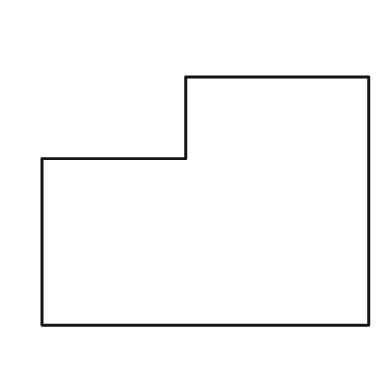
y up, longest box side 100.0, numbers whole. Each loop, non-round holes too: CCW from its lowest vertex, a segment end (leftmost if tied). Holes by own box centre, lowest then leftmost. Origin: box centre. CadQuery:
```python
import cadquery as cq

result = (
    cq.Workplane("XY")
    .moveTo(-50.0, -38.0)
    .lineTo(50.0, -38.0)
    .lineTo(50.0, 38.0)
    .lineTo(-6.0, 38.0)
    .lineTo(-6.0, 13.0)
    .lineTo(-50.0, 13.0)
    .close()
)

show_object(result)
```